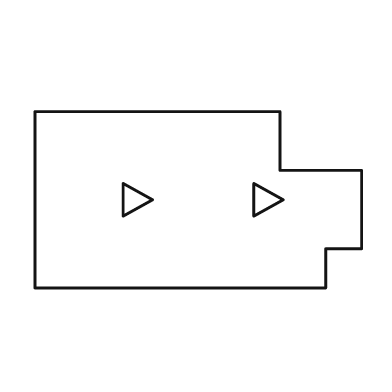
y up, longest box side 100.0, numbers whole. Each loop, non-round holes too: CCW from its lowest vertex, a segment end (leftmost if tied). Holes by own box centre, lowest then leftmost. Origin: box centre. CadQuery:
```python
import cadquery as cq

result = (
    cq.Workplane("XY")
    .moveTo(-50.0, -27.0)
    .lineTo(39.0, -27.0)
    .lineTo(39.0, -15.0)
    .lineTo(50.0, -15.0)
    .lineTo(50.0, 9.0)
    .lineTo(25.0, 9.0)
    .lineTo(25.0, 27.0)
    .lineTo(-50.0, 27.0)
    .close()
    .moveTo(-23.0, -5.0)
    .lineTo(-14.0, 0.0)
    .lineTo(-23.0, 5.0)
    .close()
    .moveTo(17.0, -5.0)
    .lineTo(26.0, 0.0)
    .lineTo(17.0, 5.0)
    .close()
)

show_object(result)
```